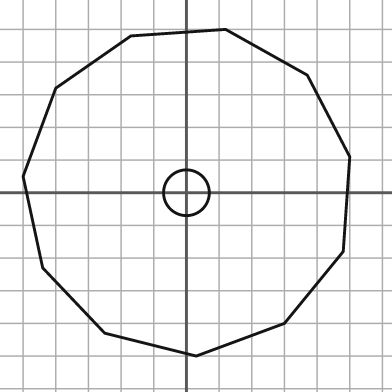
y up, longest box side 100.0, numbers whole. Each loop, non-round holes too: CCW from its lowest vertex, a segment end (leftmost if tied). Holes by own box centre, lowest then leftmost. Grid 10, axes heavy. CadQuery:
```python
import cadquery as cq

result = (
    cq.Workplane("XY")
    .moveTo(3.0, -50.0)
    .lineTo(30.0, -40.0)
    .lineTo(48.0, -18.0)
    .lineTo(50.0, 11.0)
    .lineTo(37.0, 36.0)
    .lineTo(12.0, 50.0)
    .lineTo(-17.0, 48.0)
    .lineTo(-40.0, 32.0)
    .lineTo(-50.0, 5.0)
    .lineTo(-44.0, -23.0)
    .lineTo(-25.0, -43.0)
    .close()
    .moveTo(0.0, 0.0)
    .circle(7.0)
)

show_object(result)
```